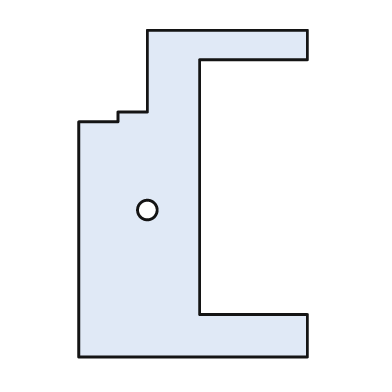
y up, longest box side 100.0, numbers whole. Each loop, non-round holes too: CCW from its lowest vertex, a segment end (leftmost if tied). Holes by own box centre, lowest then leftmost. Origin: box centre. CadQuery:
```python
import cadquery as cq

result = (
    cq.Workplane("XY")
    .moveTo(-35.0, -50.0)
    .lineTo(35.0, -50.0)
    .lineTo(35.0, -37.0)
    .lineTo(2.0, -37.0)
    .lineTo(2.0, 41.0)
    .lineTo(35.0, 41.0)
    .lineTo(35.0, 50.0)
    .lineTo(-14.0, 50.0)
    .lineTo(-14.0, 25.0)
    .lineTo(-23.0, 25.0)
    .lineTo(-23.0, 22.0)
    .lineTo(-35.0, 22.0)
    .close()
    .moveTo(-14.0, -5.0)
    .circle(3.0)
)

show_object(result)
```